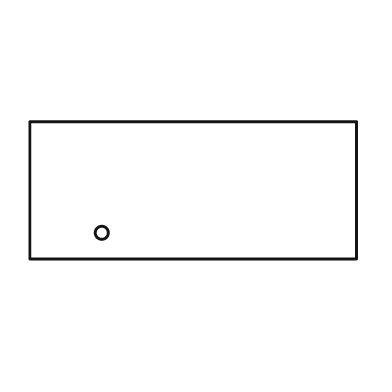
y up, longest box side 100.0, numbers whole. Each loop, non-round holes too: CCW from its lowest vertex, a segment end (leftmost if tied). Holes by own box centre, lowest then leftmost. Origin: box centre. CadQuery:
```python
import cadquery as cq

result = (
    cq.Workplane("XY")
    .moveTo(-50.0, -21.0)
    .lineTo(50.0, -21.0)
    .lineTo(50.0, 21.0)
    .lineTo(-50.0, 21.0)
    .close()
    .moveTo(-28.0, -13.0)
    .circle(2.0)
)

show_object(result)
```